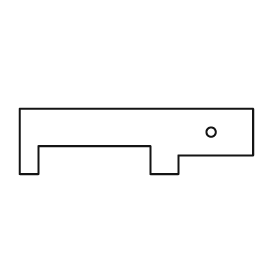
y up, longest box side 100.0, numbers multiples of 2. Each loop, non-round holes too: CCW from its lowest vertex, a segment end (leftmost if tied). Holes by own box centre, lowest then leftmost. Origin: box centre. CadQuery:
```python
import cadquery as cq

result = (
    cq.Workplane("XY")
    .moveTo(-50.0, -14.0)
    .lineTo(-42.0, -14.0)
    .lineTo(-42.0, -2.0)
    .lineTo(6.0, -2.0)
    .lineTo(6.0, -14.0)
    .lineTo(18.0, -14.0)
    .lineTo(18.0, -6.0)
    .lineTo(50.0, -6.0)
    .lineTo(50.0, 14.0)
    .lineTo(-50.0, 14.0)
    .close()
    .moveTo(32.0, 4.0)
    .circle(2.0)
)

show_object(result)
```